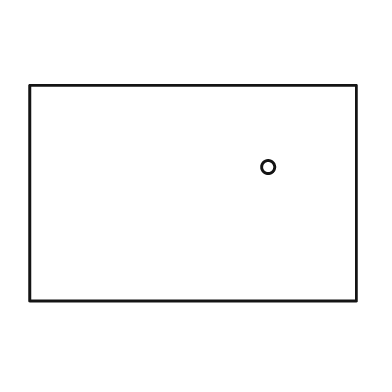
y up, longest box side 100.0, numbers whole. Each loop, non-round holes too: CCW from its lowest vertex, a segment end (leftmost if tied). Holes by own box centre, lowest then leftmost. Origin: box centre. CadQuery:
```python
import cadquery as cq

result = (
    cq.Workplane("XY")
    .moveTo(-50.0, -33.0)
    .lineTo(50.0, -33.0)
    .lineTo(50.0, 33.0)
    .lineTo(-50.0, 33.0)
    .close()
    .moveTo(23.0, 8.0)
    .circle(2.0)
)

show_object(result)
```